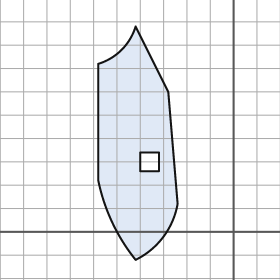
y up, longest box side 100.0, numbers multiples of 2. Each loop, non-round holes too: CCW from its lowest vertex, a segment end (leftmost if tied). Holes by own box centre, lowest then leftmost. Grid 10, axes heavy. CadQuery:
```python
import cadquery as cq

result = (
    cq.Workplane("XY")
    .moveTo(-42.0, -12.0)
    .threePointArc((-30.0, -2.0), (-24.0, 12.0))
    .lineTo(-28.0, 60.0)
    .lineTo(-42.0, 88.0)
    .threePointArc((-48.0, 78.0), (-58.0, 72.0))
    .lineTo(-58.0, 22.0)
    .threePointArc((-52.0, 4.0), (-42.0, -12.0))
    .close()
    .moveTo(-40.0, 26.0)
    .lineTo(-32.0, 26.0)
    .lineTo(-32.0, 34.0)
    .lineTo(-40.0, 34.0)
    .close()
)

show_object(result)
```